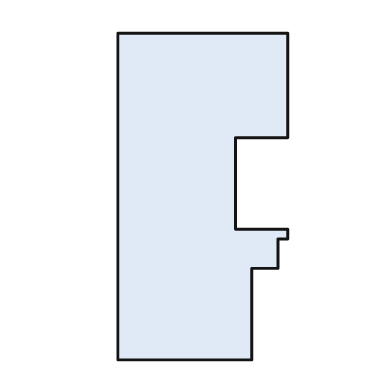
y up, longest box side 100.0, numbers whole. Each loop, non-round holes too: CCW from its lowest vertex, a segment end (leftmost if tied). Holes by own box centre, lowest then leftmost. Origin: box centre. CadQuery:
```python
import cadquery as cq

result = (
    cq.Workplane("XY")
    .moveTo(-26.0, -50.0)
    .lineTo(15.0, -50.0)
    .lineTo(15.0, -22.0)
    .lineTo(23.0, -22.0)
    .lineTo(23.0, -13.0)
    .lineTo(26.0, -13.0)
    .lineTo(26.0, -10.0)
    .lineTo(10.0, -10.0)
    .lineTo(10.0, 18.0)
    .lineTo(26.0, 18.0)
    .lineTo(26.0, 50.0)
    .lineTo(-26.0, 50.0)
    .close()
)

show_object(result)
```